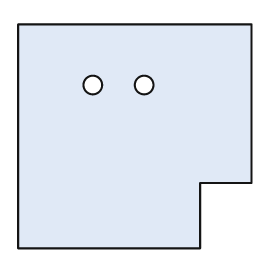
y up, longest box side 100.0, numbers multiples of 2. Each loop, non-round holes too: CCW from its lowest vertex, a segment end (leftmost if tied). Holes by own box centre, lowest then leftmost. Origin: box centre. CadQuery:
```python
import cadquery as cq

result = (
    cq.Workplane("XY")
    .moveTo(-50.0, -48.0)
    .lineTo(28.0, -48.0)
    .lineTo(28.0, -20.0)
    .lineTo(50.0, -20.0)
    .lineTo(50.0, 48.0)
    .lineTo(-50.0, 48.0)
    .close()
    .moveTo(-18.0, 22.0)
    .circle(4.0)
    .moveTo(4.0, 22.0)
    .circle(4.0)
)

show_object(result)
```